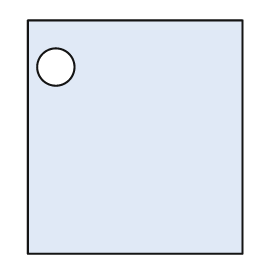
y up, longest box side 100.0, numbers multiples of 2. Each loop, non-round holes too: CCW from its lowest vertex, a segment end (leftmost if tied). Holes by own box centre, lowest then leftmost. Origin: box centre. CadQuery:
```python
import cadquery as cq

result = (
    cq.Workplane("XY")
    .moveTo(-46.0, -50.0)
    .lineTo(46.0, -50.0)
    .lineTo(46.0, 50.0)
    .lineTo(-46.0, 50.0)
    .close()
    .moveTo(-34.0, 30.0)
    .circle(8.0)
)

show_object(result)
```